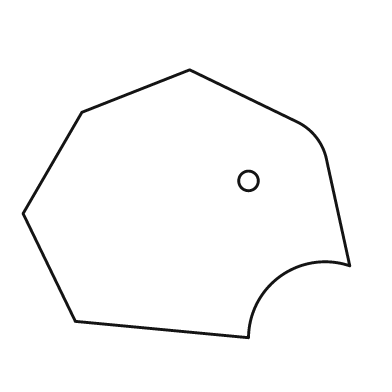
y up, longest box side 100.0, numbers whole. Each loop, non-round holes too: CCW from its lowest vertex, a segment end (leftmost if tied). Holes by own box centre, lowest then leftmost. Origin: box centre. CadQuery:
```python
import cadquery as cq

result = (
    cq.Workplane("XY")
    .moveTo(19.0, -41.0)
    .threePointArc((29.0, -22.0), (50.0, -19.0))
    .lineTo(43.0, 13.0)
    .threePointArc((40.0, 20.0), (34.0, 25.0))
    .lineTo(1.0, 41.0)
    .lineTo(-32.0, 28.0)
    .lineTo(-50.0, -3.0)
    .lineTo(-34.0, -36.0)
    .close()
    .moveTo(19.0, 7.0)
    .circle(3.0)
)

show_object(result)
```